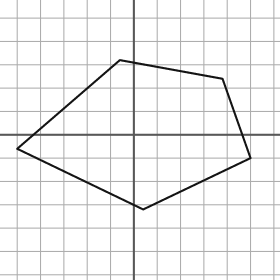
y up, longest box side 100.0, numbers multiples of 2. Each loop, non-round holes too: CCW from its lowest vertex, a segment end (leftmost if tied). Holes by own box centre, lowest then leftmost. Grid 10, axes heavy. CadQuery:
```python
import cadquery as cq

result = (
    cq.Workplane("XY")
    .moveTo(4.0, -32.0)
    .lineTo(50.0, -10.0)
    .lineTo(38.0, 24.0)
    .lineTo(-6.0, 32.0)
    .lineTo(-50.0, -6.0)
    .close()
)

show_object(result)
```